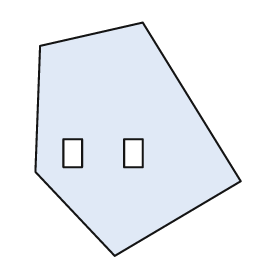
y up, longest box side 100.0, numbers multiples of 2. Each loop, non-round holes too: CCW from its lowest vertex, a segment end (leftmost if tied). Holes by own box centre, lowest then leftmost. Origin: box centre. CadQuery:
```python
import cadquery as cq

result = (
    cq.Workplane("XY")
    .moveTo(-10.0, -50.0)
    .lineTo(44.0, -18.0)
    .lineTo(2.0, 50.0)
    .lineTo(-42.0, 40.0)
    .lineTo(-44.0, -14.0)
    .close()
    .moveTo(-32.0, -12.0)
    .lineTo(-24.0, -12.0)
    .lineTo(-24.0, 0.0)
    .lineTo(-32.0, 0.0)
    .close()
    .moveTo(-6.0, -12.0)
    .lineTo(2.0, -12.0)
    .lineTo(2.0, 0.0)
    .lineTo(-6.0, 0.0)
    .close()
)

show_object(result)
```